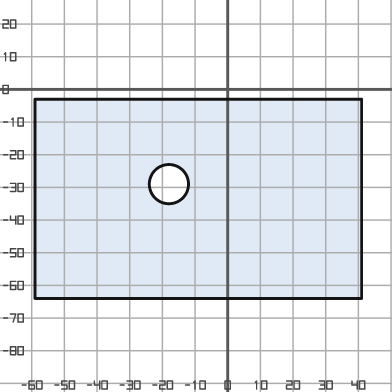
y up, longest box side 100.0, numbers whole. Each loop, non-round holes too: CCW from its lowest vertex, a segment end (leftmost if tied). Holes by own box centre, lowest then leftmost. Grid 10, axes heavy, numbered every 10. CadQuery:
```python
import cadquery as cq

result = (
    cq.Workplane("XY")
    .moveTo(-59.0, -64.0)
    .lineTo(41.0, -64.0)
    .lineTo(41.0, -3.0)
    .lineTo(-59.0, -3.0)
    .close()
    .moveTo(-18.0, -29.0)
    .circle(6.0)
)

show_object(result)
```